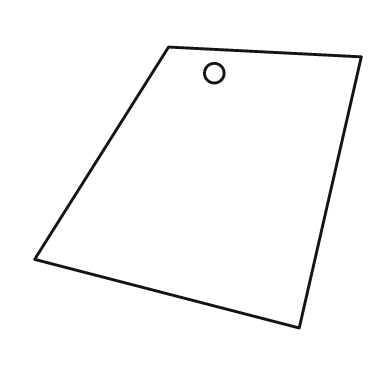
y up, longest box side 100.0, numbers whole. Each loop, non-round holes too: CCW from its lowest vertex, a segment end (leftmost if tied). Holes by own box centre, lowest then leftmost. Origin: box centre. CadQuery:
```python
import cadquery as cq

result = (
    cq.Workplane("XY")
    .moveTo(31.0, -43.0)
    .lineTo(50.0, 40.0)
    .lineTo(-9.0, 43.0)
    .lineTo(-50.0, -22.0)
    .close()
    .moveTo(5.0, 35.0)
    .circle(3.0)
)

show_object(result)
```